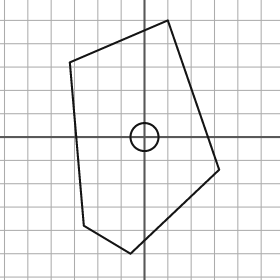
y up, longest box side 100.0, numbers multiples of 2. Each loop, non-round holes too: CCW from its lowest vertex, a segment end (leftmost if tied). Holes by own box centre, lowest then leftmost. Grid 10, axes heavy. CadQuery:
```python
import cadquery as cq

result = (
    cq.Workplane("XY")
    .moveTo(-6.0, -50.0)
    .lineTo(32.0, -14.0)
    .lineTo(10.0, 50.0)
    .lineTo(-32.0, 32.0)
    .lineTo(-26.0, -38.0)
    .close()
    .moveTo(0.0, 0.0)
    .circle(6.0)
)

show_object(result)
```